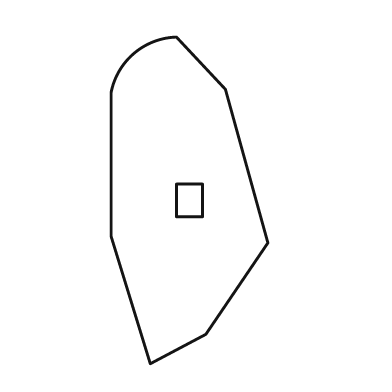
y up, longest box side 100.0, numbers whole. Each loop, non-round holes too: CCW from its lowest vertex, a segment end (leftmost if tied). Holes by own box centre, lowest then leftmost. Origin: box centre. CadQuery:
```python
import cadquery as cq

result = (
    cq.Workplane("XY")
    .moveTo(-12.0, -50.0)
    .lineTo(5.0, -41.0)
    .lineTo(24.0, -13.0)
    .lineTo(11.0, 34.0)
    .lineTo(-4.0, 50.0)
    .threePointArc((-17.0, 45.0), (-24.0, 33.0))
    .lineTo(-24.0, -11.0)
    .close()
    .moveTo(-4.0, -5.0)
    .lineTo(4.0, -5.0)
    .lineTo(4.0, 5.0)
    .lineTo(-4.0, 5.0)
    .close()
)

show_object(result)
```